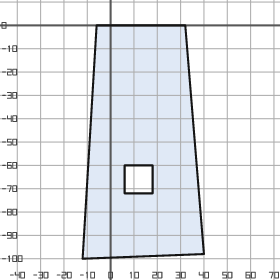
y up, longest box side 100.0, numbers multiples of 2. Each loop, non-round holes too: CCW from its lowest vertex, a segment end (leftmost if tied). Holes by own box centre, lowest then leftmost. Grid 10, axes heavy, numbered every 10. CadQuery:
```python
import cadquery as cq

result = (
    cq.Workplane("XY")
    .moveTo(-12.0, -100.0)
    .lineTo(40.0, -98.0)
    .lineTo(32.0, 0.0)
    .lineTo(-6.0, 0.0)
    .close()
    .moveTo(6.0, -72.0)
    .lineTo(18.0, -72.0)
    .lineTo(18.0, -60.0)
    .lineTo(6.0, -60.0)
    .close()
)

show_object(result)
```